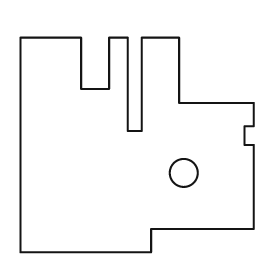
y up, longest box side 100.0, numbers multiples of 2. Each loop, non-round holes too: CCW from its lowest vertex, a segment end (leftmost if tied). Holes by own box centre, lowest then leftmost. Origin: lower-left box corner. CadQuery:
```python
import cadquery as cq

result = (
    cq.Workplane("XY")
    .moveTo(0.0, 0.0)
    .lineTo(56.0, 0.0)
    .lineTo(56.0, 10.0)
    .lineTo(100.0, 10.0)
    .lineTo(100.0, 46.0)
    .lineTo(96.0, 46.0)
    .lineTo(96.0, 54.0)
    .lineTo(100.0, 54.0)
    .lineTo(100.0, 64.0)
    .lineTo(68.0, 64.0)
    .lineTo(68.0, 92.0)
    .lineTo(52.0, 92.0)
    .lineTo(52.0, 52.0)
    .lineTo(46.0, 52.0)
    .lineTo(46.0, 92.0)
    .lineTo(38.0, 92.0)
    .lineTo(38.0, 70.0)
    .lineTo(26.0, 70.0)
    .lineTo(26.0, 92.0)
    .lineTo(0.0, 92.0)
    .close()
    .moveTo(70.0, 34.0)
    .circle(6.0)
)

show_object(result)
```